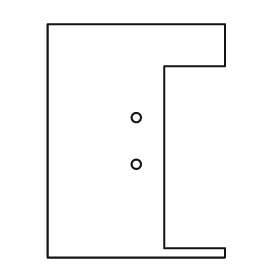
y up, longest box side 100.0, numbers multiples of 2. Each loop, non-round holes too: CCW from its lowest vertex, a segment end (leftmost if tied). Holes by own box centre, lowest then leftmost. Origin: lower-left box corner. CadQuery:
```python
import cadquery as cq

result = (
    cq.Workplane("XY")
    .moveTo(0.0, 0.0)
    .lineTo(76.0, 0.0)
    .lineTo(76.0, 4.0)
    .lineTo(50.0, 4.0)
    .lineTo(50.0, 82.0)
    .lineTo(76.0, 82.0)
    .lineTo(76.0, 100.0)
    .lineTo(0.0, 100.0)
    .close()
    .moveTo(38.0, 40.0)
    .circle(2.0)
    .moveTo(38.0, 60.0)
    .circle(2.0)
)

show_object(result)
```